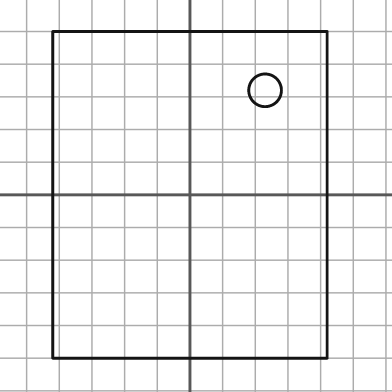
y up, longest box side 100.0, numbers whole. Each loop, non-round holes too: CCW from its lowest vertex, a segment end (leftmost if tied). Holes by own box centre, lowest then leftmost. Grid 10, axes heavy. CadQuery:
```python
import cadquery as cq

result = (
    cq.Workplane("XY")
    .moveTo(-42.0, -50.0)
    .lineTo(42.0, -50.0)
    .lineTo(42.0, 50.0)
    .lineTo(-42.0, 50.0)
    .close()
    .moveTo(23.0, 32.0)
    .circle(5.0)
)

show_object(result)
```